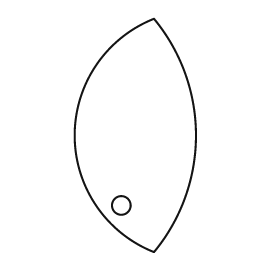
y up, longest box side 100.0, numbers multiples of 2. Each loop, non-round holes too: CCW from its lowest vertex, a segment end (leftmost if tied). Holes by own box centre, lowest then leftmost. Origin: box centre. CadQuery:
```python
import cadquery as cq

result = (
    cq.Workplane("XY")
    .moveTo(8.0, -50.0)
    .threePointArc((26.0, 0.0), (8.0, 50.0))
    .threePointArc((-26.0, 0.0), (8.0, -50.0))
    .close()
    .moveTo(-6.0, -30.0)
    .circle(4.0)
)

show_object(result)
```